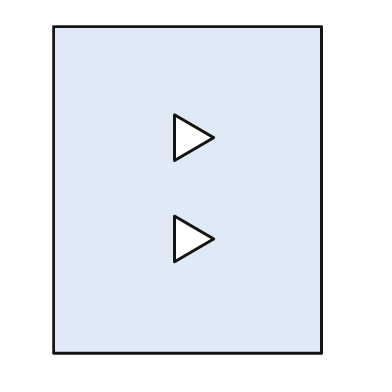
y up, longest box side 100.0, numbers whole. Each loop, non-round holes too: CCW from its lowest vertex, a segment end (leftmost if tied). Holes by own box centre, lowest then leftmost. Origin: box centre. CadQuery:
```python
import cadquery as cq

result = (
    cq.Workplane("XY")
    .moveTo(-41.0, -50.0)
    .lineTo(41.0, -50.0)
    .lineTo(41.0, 50.0)
    .lineTo(-41.0, 50.0)
    .close()
    .moveTo(-4.0, -22.0)
    .lineTo(8.0, -15.0)
    .lineTo(-4.0, -8.0)
    .close()
    .moveTo(-4.0, 9.0)
    .lineTo(8.0, 16.0)
    .lineTo(-4.0, 23.0)
    .close()
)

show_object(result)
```